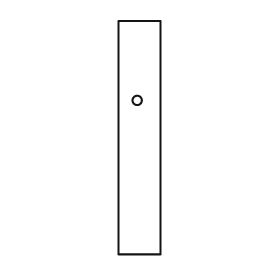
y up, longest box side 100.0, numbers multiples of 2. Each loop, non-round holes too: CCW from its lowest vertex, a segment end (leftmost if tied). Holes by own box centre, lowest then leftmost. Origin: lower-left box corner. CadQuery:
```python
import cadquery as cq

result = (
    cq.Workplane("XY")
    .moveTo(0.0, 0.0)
    .lineTo(18.0, 0.0)
    .lineTo(18.0, 100.0)
    .lineTo(0.0, 100.0)
    .close()
    .moveTo(8.0, 66.0)
    .circle(2.0)
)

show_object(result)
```